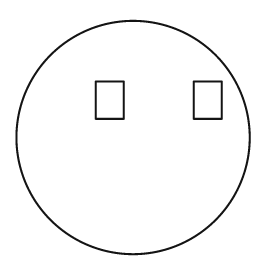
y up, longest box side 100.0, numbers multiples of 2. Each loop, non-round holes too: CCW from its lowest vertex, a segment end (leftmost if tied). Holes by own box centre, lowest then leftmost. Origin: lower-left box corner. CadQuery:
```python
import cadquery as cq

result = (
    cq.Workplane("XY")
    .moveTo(50.0, 50.0)
    .circle(50.0)
    .moveTo(34.0, 58.0)
    .lineTo(46.0, 58.0)
    .lineTo(46.0, 74.0)
    .lineTo(34.0, 74.0)
    .close()
    .moveTo(76.0, 58.0)
    .lineTo(88.0, 58.0)
    .lineTo(88.0, 74.0)
    .lineTo(76.0, 74.0)
    .close()
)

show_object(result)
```